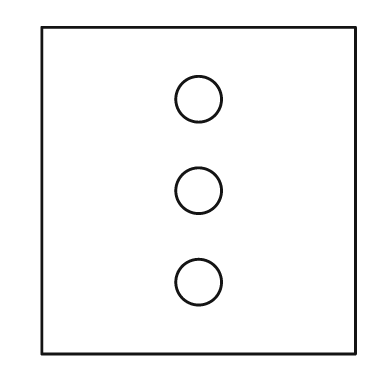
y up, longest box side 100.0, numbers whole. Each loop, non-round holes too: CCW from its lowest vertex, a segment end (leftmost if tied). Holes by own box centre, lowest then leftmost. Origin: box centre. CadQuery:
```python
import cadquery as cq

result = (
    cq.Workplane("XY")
    .moveTo(-48.0, -50.0)
    .lineTo(48.0, -50.0)
    .lineTo(48.0, 50.0)
    .lineTo(-48.0, 50.0)
    .close()
    .moveTo(0.0, -28.0)
    .circle(7.0)
    .moveTo(0.0, 0.0)
    .circle(7.0)
    .moveTo(0.0, 28.0)
    .circle(7.0)
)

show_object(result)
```